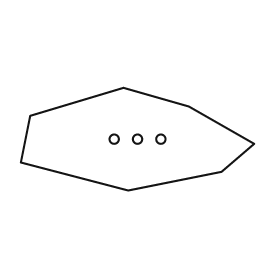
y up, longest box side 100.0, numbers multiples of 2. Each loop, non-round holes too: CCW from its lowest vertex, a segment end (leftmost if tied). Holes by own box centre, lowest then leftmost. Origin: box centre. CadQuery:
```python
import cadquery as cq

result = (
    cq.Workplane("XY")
    .moveTo(-4.0, -22.0)
    .lineTo(36.0, -14.0)
    .lineTo(50.0, -2.0)
    .lineTo(22.0, 14.0)
    .lineTo(-6.0, 22.0)
    .lineTo(-46.0, 10.0)
    .lineTo(-50.0, -10.0)
    .close()
    .moveTo(-10.0, 0.0)
    .circle(2.0)
    .moveTo(0.0, 0.0)
    .circle(2.0)
    .moveTo(10.0, 0.0)
    .circle(2.0)
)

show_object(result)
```